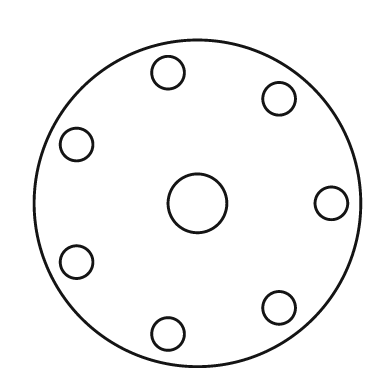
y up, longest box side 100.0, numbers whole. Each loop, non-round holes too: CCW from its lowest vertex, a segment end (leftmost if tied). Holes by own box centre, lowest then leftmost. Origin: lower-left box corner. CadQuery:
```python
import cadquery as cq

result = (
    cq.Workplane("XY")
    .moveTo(50.0, 50.0)
    .circle(50.0)
    .moveTo(41.0, 10.0)
    .circle(5.0)
    .moveTo(75.0, 18.0)
    .circle(5.0)
    .moveTo(13.0, 32.0)
    .circle(5.0)
    .moveTo(50.0, 50.0)
    .circle(9.0)
    .moveTo(91.0, 50.0)
    .circle(5.0)
    .moveTo(13.0, 68.0)
    .circle(5.0)
    .moveTo(75.0, 82.0)
    .circle(5.0)
    .moveTo(41.0, 90.0)
    .circle(5.0)
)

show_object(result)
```